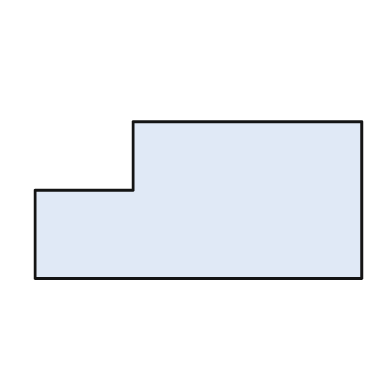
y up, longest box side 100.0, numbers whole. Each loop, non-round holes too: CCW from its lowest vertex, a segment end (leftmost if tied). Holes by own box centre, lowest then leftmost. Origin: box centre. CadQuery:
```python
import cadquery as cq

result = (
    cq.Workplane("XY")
    .moveTo(-50.0, -24.0)
    .lineTo(50.0, -24.0)
    .lineTo(50.0, 24.0)
    .lineTo(-20.0, 24.0)
    .lineTo(-20.0, 3.0)
    .lineTo(-50.0, 3.0)
    .close()
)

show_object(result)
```